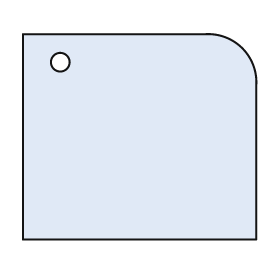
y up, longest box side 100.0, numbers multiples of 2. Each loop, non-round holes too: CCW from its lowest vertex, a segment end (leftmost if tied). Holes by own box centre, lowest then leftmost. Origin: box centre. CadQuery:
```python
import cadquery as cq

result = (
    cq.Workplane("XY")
    .moveTo(-50.0, -44.0)
    .lineTo(50.0, -44.0)
    .lineTo(50.0, 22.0)
    .threePointArc((44.0, 38.0), (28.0, 44.0))
    .lineTo(-50.0, 44.0)
    .close()
    .moveTo(-34.0, 32.0)
    .circle(4.0)
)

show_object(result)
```